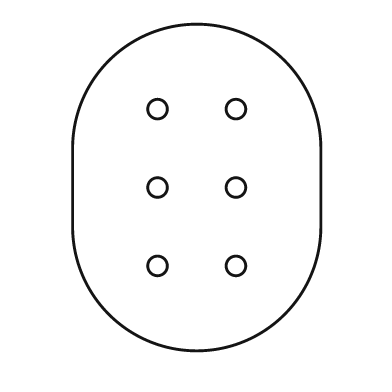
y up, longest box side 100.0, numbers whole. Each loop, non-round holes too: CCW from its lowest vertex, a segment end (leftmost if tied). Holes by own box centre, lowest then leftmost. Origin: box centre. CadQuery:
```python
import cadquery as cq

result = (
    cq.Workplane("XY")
    .moveTo(-38.0, -12.0)
    .threePointArc((0.0, -50.0), (38.0, -12.0))
    .lineTo(38.0, 12.0)
    .threePointArc((0.0, 50.0), (-38.0, 12.0))
    .close()
    .moveTo(-12.0, -24.0)
    .circle(3.0)
    .moveTo(12.0, -24.0)
    .circle(3.0)
    .moveTo(-12.0, 0.0)
    .circle(3.0)
    .moveTo(12.0, 0.0)
    .circle(3.0)
    .moveTo(-12.0, 24.0)
    .circle(3.0)
    .moveTo(12.0, 24.0)
    .circle(3.0)
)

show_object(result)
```